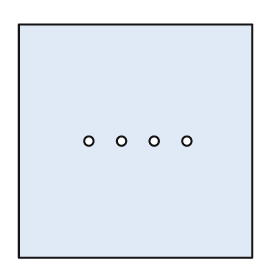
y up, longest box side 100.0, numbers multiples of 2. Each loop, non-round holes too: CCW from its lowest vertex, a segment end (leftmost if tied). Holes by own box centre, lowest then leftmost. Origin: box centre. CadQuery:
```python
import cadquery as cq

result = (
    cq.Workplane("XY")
    .moveTo(-50.0, -50.0)
    .lineTo(50.0, -50.0)
    .lineTo(50.0, 50.0)
    .lineTo(-50.0, 50.0)
    .close()
    .moveTo(-20.0, 0.0)
    .circle(2.0)
    .moveTo(-6.0, 0.0)
    .circle(2.0)
    .moveTo(8.0, 0.0)
    .circle(2.0)
    .moveTo(22.0, 0.0)
    .circle(2.0)
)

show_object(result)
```